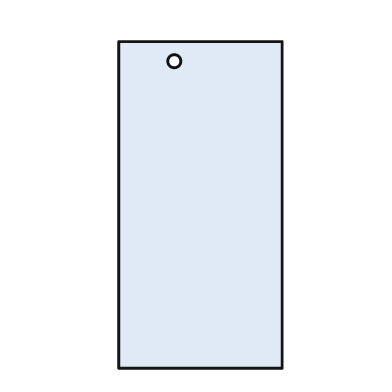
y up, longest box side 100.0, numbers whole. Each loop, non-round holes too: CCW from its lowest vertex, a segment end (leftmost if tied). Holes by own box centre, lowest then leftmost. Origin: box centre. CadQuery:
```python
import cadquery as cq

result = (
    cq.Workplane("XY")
    .moveTo(-25.0, -50.0)
    .lineTo(25.0, -50.0)
    .lineTo(25.0, 50.0)
    .lineTo(-25.0, 50.0)
    .close()
    .moveTo(-8.0, 44.0)
    .circle(2.0)
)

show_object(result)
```